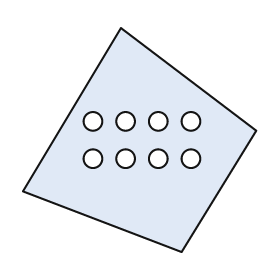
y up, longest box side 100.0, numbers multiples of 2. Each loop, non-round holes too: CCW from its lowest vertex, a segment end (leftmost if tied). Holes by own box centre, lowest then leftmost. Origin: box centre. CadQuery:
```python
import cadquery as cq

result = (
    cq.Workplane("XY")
    .moveTo(18.0, -48.0)
    .lineTo(50.0, 4.0)
    .lineTo(-8.0, 48.0)
    .lineTo(-50.0, -22.0)
    .close()
    .moveTo(-20.0, -8.0)
    .circle(4.0)
    .moveTo(-6.0, -8.0)
    .circle(4.0)
    .moveTo(8.0, -8.0)
    .circle(4.0)
    .moveTo(22.0, -8.0)
    .circle(4.0)
    .moveTo(-20.0, 8.0)
    .circle(4.0)
    .moveTo(-6.0, 8.0)
    .circle(4.0)
    .moveTo(8.0, 8.0)
    .circle(4.0)
    .moveTo(22.0, 8.0)
    .circle(4.0)
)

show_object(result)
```